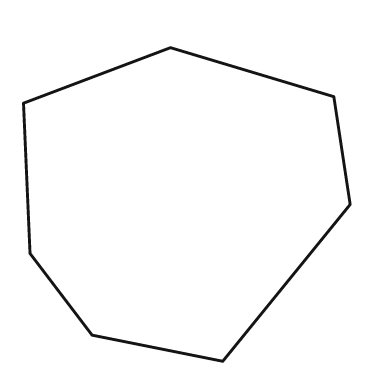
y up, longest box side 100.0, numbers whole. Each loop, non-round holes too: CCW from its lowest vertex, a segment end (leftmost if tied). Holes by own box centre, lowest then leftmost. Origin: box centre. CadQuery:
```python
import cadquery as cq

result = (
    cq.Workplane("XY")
    .moveTo(11.0, -48.0)
    .lineTo(50.0, 0.0)
    .lineTo(45.0, 33.0)
    .lineTo(-5.0, 48.0)
    .lineTo(-50.0, 31.0)
    .lineTo(-48.0, -15.0)
    .lineTo(-29.0, -40.0)
    .close()
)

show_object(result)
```